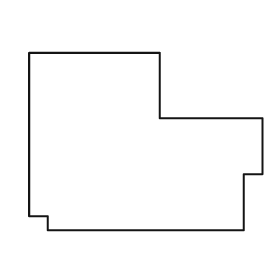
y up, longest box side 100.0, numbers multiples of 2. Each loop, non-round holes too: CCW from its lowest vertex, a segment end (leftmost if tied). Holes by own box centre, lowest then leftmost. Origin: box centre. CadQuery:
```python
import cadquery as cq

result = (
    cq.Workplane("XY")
    .moveTo(-42.0, -38.0)
    .lineTo(42.0, -38.0)
    .lineTo(42.0, -14.0)
    .lineTo(50.0, -14.0)
    .lineTo(50.0, 10.0)
    .lineTo(6.0, 10.0)
    .lineTo(6.0, 38.0)
    .lineTo(-50.0, 38.0)
    .lineTo(-50.0, -32.0)
    .lineTo(-42.0, -32.0)
    .close()
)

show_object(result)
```